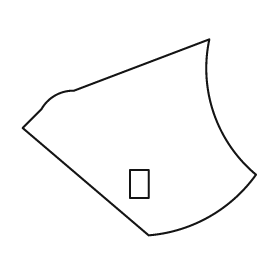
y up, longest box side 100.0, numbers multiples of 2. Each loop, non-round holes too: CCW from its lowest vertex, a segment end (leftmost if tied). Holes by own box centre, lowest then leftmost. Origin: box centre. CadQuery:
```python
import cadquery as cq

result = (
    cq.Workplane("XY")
    .moveTo(4.0, -42.0)
    .threePointArc((30.0, -34.0), (50.0, -16.0))
    .threePointArc((32.0, 10.0), (30.0, 42.0))
    .lineTo(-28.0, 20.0)
    .threePointArc((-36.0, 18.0), (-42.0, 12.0))
    .lineTo(-50.0, 4.0)
    .close()
    .moveTo(-4.0, -26.0)
    .lineTo(4.0, -26.0)
    .lineTo(4.0, -14.0)
    .lineTo(-4.0, -14.0)
    .close()
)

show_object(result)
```